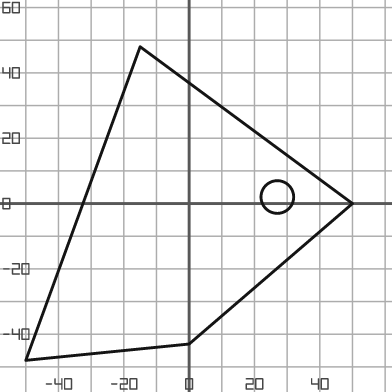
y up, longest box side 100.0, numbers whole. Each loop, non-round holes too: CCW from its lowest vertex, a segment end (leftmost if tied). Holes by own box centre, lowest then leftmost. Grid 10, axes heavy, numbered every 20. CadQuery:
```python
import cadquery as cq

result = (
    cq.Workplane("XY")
    .moveTo(-50.0, -48.0)
    .lineTo(0.0, -43.0)
    .lineTo(50.0, 0.0)
    .lineTo(-15.0, 48.0)
    .close()
    .moveTo(27.0, 2.0)
    .circle(5.0)
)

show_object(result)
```